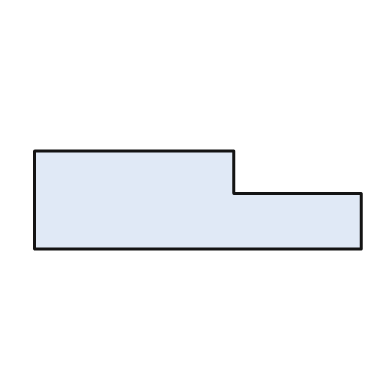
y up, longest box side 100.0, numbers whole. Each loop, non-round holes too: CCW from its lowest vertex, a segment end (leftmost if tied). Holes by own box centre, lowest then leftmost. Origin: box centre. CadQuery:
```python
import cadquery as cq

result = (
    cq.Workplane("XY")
    .moveTo(-50.0, -15.0)
    .lineTo(50.0, -15.0)
    .lineTo(50.0, 2.0)
    .lineTo(11.0, 2.0)
    .lineTo(11.0, 15.0)
    .lineTo(-50.0, 15.0)
    .close()
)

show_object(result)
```